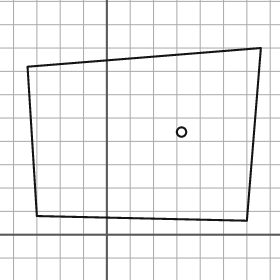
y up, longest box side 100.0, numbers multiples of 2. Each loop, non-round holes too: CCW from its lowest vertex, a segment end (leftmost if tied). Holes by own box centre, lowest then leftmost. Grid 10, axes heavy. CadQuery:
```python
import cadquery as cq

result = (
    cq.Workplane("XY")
    .moveTo(60.0, 6.0)
    .lineTo(66.0, 80.0)
    .lineTo(-34.0, 72.0)
    .lineTo(-30.0, 8.0)
    .close()
    .moveTo(32.0, 44.0)
    .circle(2.0)
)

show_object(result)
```